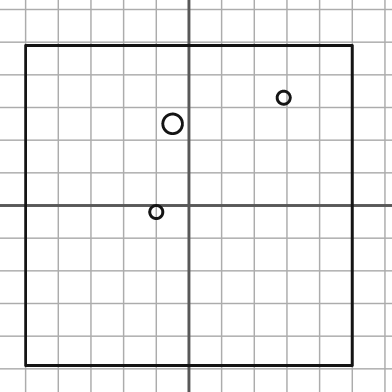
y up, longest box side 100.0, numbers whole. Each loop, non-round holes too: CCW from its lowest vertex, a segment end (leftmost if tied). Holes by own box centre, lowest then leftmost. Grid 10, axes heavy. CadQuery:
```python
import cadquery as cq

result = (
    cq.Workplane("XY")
    .moveTo(-50.0, -49.0)
    .lineTo(50.0, -49.0)
    .lineTo(50.0, 49.0)
    .lineTo(-50.0, 49.0)
    .close()
    .moveTo(-10.0, -2.0)
    .circle(2.0)
    .moveTo(-5.0, 25.0)
    .circle(3.0)
    .moveTo(29.0, 33.0)
    .circle(2.0)
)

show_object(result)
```